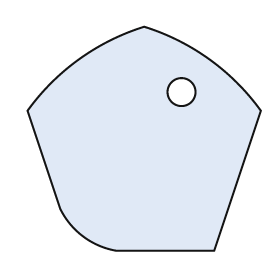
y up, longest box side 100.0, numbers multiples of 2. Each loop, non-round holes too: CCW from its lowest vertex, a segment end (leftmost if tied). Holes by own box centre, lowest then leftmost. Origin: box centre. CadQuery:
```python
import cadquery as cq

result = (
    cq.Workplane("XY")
    .moveTo(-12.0, -48.0)
    .lineTo(30.0, -48.0)
    .lineTo(50.0, 12.0)
    .threePointArc((28.0, 34.0), (0.0, 48.0))
    .threePointArc((-28.0, 34.0), (-50.0, 12.0))
    .lineTo(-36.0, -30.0)
    .threePointArc((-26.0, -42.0), (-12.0, -48.0))
    .close()
    .moveTo(16.0, 20.0)
    .circle(6.0)
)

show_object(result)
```